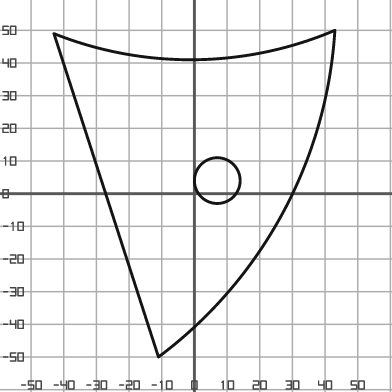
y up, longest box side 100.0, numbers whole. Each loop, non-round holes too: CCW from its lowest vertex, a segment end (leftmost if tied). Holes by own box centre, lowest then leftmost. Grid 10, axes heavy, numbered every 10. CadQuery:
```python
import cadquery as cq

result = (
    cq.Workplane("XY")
    .moveTo(-11.0, -50.0)
    .threePointArc((27.0, -6.0), (43.0, 50.0))
    .threePointArc((0.0, 41.0), (-43.0, 49.0))
    .close()
    .moveTo(7.0, 4.0)
    .circle(7.0)
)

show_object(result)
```